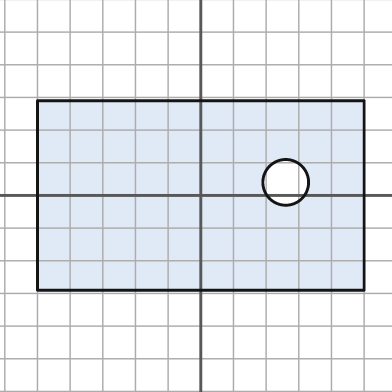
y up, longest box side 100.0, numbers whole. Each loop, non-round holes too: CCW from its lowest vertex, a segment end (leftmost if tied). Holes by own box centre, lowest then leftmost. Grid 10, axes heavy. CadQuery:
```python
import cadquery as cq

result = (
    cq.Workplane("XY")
    .moveTo(-50.0, -29.0)
    .lineTo(50.0, -29.0)
    .lineTo(50.0, 29.0)
    .lineTo(-50.0, 29.0)
    .close()
    .moveTo(26.0, 4.0)
    .circle(7.0)
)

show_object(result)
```